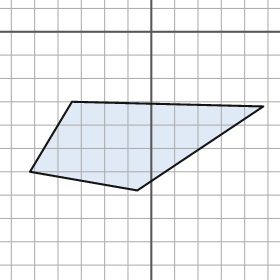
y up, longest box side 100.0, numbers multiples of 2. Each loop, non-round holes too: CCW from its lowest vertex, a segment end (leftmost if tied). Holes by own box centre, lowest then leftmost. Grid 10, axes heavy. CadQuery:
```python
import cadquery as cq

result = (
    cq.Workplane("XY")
    .moveTo(-6.0, -68.0)
    .lineTo(48.0, -32.0)
    .lineTo(-34.0, -30.0)
    .lineTo(-52.0, -60.0)
    .close()
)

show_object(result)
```